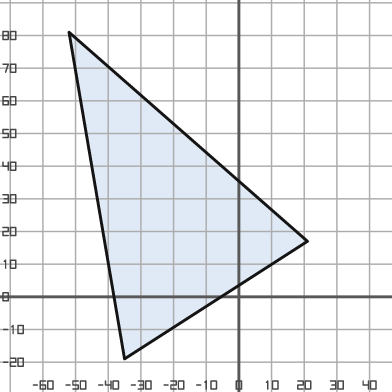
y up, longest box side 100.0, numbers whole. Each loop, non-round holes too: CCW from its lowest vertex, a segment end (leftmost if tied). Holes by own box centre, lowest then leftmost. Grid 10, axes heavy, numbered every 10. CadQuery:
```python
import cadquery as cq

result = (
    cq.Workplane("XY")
    .moveTo(-35.0, -19.0)
    .lineTo(21.0, 17.0)
    .lineTo(-52.0, 81.0)
    .close()
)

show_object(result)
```